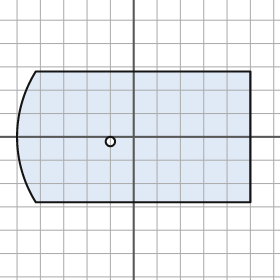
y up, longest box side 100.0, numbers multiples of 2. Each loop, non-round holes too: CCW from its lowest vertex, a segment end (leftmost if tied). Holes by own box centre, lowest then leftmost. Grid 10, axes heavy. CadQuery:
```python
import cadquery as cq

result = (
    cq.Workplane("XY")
    .moveTo(-42.0, -28.0)
    .lineTo(50.0, -28.0)
    .lineTo(50.0, 28.0)
    .lineTo(-42.0, 28.0)
    .threePointArc((-50.0, 0.0), (-42.0, -28.0))
    .close()
    .moveTo(-10.0, -2.0)
    .circle(2.0)
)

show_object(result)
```